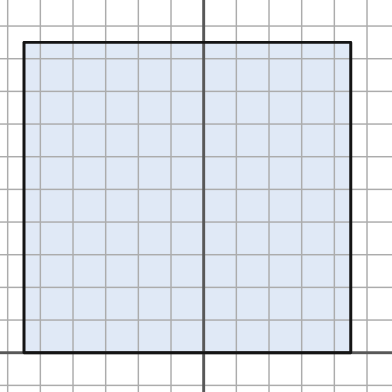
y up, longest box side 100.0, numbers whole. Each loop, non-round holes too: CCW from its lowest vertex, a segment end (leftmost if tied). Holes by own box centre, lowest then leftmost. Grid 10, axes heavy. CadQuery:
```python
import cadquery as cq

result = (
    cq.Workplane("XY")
    .moveTo(-55.0, 0.0)
    .lineTo(45.0, 0.0)
    .lineTo(45.0, 95.0)
    .lineTo(-55.0, 95.0)
    .close()
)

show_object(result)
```